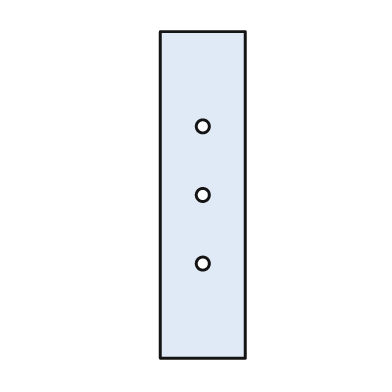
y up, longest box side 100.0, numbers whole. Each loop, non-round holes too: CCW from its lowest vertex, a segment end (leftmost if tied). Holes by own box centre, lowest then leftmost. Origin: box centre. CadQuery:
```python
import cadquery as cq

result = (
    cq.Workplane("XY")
    .moveTo(-13.0, -50.0)
    .lineTo(13.0, -50.0)
    .lineTo(13.0, 50.0)
    .lineTo(-13.0, 50.0)
    .close()
    .moveTo(0.0, -21.0)
    .circle(2.0)
    .moveTo(0.0, 0.0)
    .circle(2.0)
    .moveTo(0.0, 21.0)
    .circle(2.0)
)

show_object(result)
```